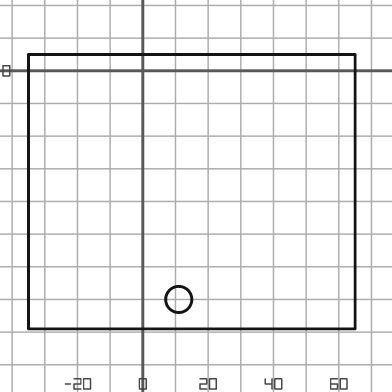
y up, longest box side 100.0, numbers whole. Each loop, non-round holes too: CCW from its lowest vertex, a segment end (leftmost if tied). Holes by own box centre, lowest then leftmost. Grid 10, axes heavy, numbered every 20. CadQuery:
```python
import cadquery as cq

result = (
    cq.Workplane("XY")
    .moveTo(-35.0, -79.0)
    .lineTo(65.0, -79.0)
    .lineTo(65.0, 5.0)
    .lineTo(-35.0, 5.0)
    .close()
    .moveTo(11.0, -70.0)
    .circle(4.0)
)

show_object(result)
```